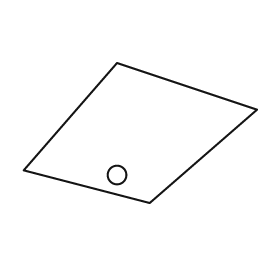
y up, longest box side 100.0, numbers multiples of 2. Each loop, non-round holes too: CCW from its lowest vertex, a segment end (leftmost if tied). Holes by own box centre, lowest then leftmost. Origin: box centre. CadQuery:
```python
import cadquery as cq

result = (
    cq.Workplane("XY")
    .moveTo(4.0, -30.0)
    .lineTo(50.0, 10.0)
    .lineTo(-10.0, 30.0)
    .lineTo(-50.0, -16.0)
    .close()
    .moveTo(-10.0, -18.0)
    .circle(4.0)
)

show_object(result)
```